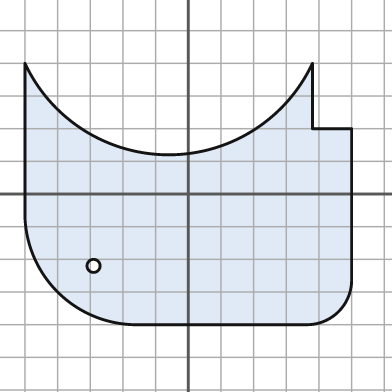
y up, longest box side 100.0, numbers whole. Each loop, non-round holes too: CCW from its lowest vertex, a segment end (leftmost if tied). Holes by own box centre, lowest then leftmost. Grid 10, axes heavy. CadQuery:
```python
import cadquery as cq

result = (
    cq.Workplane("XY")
    .moveTo(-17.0, -40.0)
    .lineTo(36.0, -40.0)
    .threePointArc((46.0, -36.0), (50.0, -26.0))
    .lineTo(50.0, 20.0)
    .lineTo(38.0, 20.0)
    .lineTo(38.0, 40.0)
    .threePointArc((-6.0, 12.0), (-50.0, 40.0))
    .lineTo(-50.0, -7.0)
    .threePointArc((-40.0, -30.0), (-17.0, -40.0))
    .close()
    .moveTo(-29.0, -22.0)
    .circle(2.0)
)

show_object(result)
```